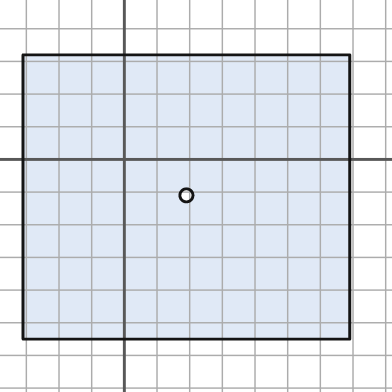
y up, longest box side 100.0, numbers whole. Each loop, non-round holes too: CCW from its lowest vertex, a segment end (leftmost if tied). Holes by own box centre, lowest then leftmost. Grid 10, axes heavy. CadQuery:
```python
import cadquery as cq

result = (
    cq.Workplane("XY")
    .moveTo(-31.0, -55.0)
    .lineTo(69.0, -55.0)
    .lineTo(69.0, 32.0)
    .lineTo(-31.0, 32.0)
    .close()
    .moveTo(19.0, -11.0)
    .circle(2.0)
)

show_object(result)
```